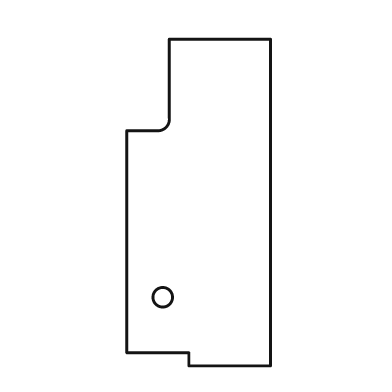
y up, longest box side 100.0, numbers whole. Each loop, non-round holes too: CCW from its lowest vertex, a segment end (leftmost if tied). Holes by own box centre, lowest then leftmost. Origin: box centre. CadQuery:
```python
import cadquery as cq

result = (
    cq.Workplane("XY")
    .moveTo(-3.0, -50.0)
    .lineTo(22.0, -50.0)
    .lineTo(22.0, 50.0)
    .lineTo(-9.0, 50.0)
    .lineTo(-9.0, 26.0)
    .threePointArc((-10.0, 23.0), (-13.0, 22.0))
    .lineTo(-22.0, 22.0)
    .lineTo(-22.0, -46.0)
    .lineTo(-3.0, -46.0)
    .close()
    .moveTo(-11.0, -29.0)
    .circle(3.0)
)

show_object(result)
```